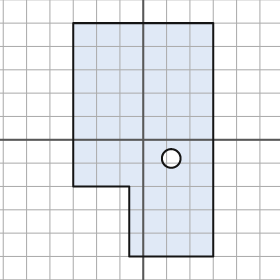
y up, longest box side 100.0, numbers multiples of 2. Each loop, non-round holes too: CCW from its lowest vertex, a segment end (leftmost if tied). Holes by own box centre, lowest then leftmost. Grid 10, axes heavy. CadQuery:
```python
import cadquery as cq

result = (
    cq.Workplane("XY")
    .moveTo(-6.0, -50.0)
    .lineTo(30.0, -50.0)
    .lineTo(30.0, 50.0)
    .lineTo(-30.0, 50.0)
    .lineTo(-30.0, -20.0)
    .lineTo(-6.0, -20.0)
    .close()
    .moveTo(12.0, -8.0)
    .circle(4.0)
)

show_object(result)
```